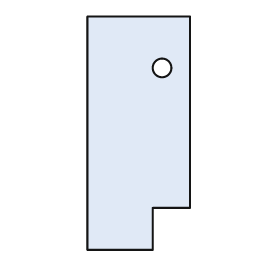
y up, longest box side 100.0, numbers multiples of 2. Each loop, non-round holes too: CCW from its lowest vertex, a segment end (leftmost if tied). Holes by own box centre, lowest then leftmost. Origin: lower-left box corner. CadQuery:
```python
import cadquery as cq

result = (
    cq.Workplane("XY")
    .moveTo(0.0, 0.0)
    .lineTo(28.0, 0.0)
    .lineTo(28.0, 18.0)
    .lineTo(44.0, 18.0)
    .lineTo(44.0, 100.0)
    .lineTo(0.0, 100.0)
    .close()
    .moveTo(32.0, 78.0)
    .circle(4.0)
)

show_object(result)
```